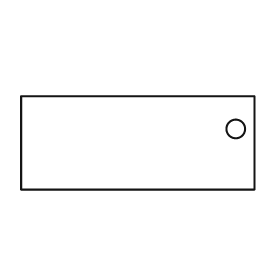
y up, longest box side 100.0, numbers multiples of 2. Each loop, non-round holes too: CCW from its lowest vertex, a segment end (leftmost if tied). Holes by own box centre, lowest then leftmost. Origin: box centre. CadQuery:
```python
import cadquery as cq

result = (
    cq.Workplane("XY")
    .moveTo(-50.0, -20.0)
    .lineTo(50.0, -20.0)
    .lineTo(50.0, 20.0)
    .lineTo(-50.0, 20.0)
    .close()
    .moveTo(42.0, 6.0)
    .circle(4.0)
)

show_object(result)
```